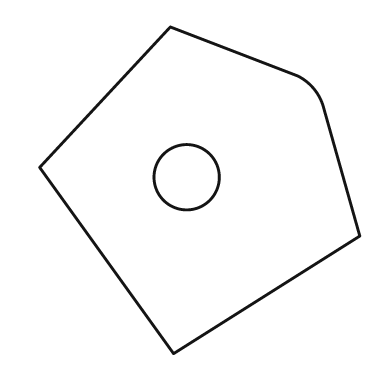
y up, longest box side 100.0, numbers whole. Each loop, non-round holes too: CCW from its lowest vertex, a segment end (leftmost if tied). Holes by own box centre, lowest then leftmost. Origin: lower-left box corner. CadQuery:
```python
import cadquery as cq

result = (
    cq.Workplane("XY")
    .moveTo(41.0, 0.0)
    .lineTo(98.0, 36.0)
    .lineTo(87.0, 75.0)
    .threePointArc((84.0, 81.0), (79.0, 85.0))
    .lineTo(40.0, 100.0)
    .lineTo(0.0, 57.0)
    .close()
    .moveTo(45.0, 54.0)
    .circle(10.0)
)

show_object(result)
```